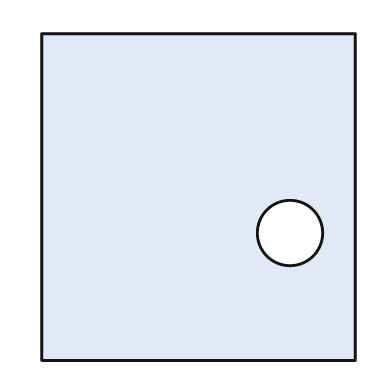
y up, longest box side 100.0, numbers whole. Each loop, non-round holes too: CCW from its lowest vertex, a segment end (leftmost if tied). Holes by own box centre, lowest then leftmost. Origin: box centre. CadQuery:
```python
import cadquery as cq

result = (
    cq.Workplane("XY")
    .moveTo(-48.0, -50.0)
    .lineTo(48.0, -50.0)
    .lineTo(48.0, 50.0)
    .lineTo(-48.0, 50.0)
    .close()
    .moveTo(28.0, -11.0)
    .circle(10.0)
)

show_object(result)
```